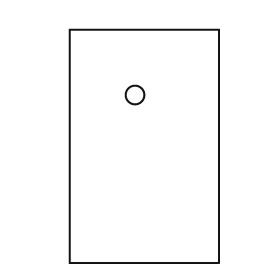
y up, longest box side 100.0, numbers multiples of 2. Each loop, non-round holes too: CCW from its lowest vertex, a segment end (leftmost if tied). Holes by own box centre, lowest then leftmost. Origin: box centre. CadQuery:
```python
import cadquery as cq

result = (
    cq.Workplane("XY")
    .moveTo(-32.0, -50.0)
    .lineTo(32.0, -50.0)
    .lineTo(32.0, 50.0)
    .lineTo(-32.0, 50.0)
    .close()
    .moveTo(-4.0, 22.0)
    .circle(4.0)
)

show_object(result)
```